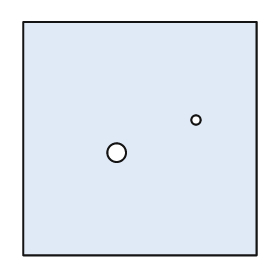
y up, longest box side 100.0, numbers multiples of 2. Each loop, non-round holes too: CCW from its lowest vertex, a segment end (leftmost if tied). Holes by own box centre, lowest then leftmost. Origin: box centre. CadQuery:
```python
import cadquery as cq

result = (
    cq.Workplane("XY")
    .moveTo(-50.0, -50.0)
    .lineTo(50.0, -50.0)
    .lineTo(50.0, 50.0)
    .lineTo(-50.0, 50.0)
    .close()
    .moveTo(-10.0, -6.0)
    .circle(4.0)
    .moveTo(24.0, 8.0)
    .circle(2.0)
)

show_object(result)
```